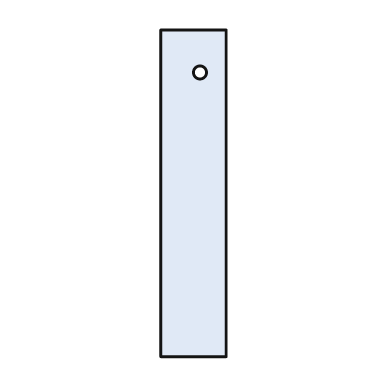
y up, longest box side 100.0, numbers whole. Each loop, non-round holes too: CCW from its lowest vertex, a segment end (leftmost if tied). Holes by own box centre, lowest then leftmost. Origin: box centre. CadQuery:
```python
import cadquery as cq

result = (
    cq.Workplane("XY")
    .moveTo(-10.0, -50.0)
    .lineTo(10.0, -50.0)
    .lineTo(10.0, 50.0)
    .lineTo(-10.0, 50.0)
    .close()
    .moveTo(2.0, 37.0)
    .circle(2.0)
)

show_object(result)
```